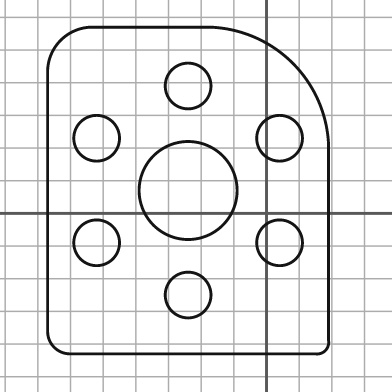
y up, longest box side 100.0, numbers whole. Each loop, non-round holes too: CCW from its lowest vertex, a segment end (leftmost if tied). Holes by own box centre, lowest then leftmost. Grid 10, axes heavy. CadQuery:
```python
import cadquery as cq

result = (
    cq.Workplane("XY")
    .moveTo(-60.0, -43.0)
    .lineTo(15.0, -43.0)
    .threePointArc((18.0, -42.0), (19.0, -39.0))
    .lineTo(19.0, 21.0)
    .threePointArc((8.0, 46.0), (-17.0, 57.0))
    .lineTo(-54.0, 57.0)
    .threePointArc((-63.0, 53.0), (-67.0, 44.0))
    .lineTo(-67.0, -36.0)
    .threePointArc((-65.0, -41.0), (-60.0, -43.0))
    .close()
    .moveTo(-24.0, -25.0)
    .circle(7.0)
    .moveTo(-52.0, -9.0)
    .circle(7.0)
    .moveTo(4.0, -9.0)
    .circle(7.0)
    .moveTo(-24.0, 7.0)
    .circle(15.0)
    .moveTo(-52.0, 23.0)
    .circle(7.0)
    .moveTo(4.0, 23.0)
    .circle(7.0)
    .moveTo(-24.0, 39.0)
    .circle(7.0)
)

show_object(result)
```